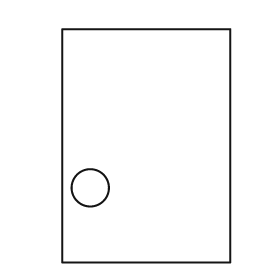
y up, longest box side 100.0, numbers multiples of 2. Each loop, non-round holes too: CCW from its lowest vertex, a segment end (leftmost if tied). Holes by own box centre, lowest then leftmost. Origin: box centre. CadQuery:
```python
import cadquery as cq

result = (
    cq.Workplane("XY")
    .moveTo(-36.0, -50.0)
    .lineTo(36.0, -50.0)
    .lineTo(36.0, 50.0)
    .lineTo(-36.0, 50.0)
    .close()
    .moveTo(-24.0, -18.0)
    .circle(8.0)
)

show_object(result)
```